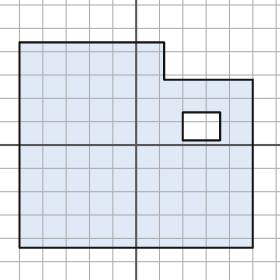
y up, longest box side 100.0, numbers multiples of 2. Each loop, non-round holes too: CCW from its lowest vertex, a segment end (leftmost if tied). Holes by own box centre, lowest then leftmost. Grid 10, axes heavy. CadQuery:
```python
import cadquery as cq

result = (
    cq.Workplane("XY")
    .moveTo(-50.0, -44.0)
    .lineTo(50.0, -44.0)
    .lineTo(50.0, 28.0)
    .lineTo(12.0, 28.0)
    .lineTo(12.0, 44.0)
    .lineTo(-50.0, 44.0)
    .close()
    .moveTo(20.0, 2.0)
    .lineTo(36.0, 2.0)
    .lineTo(36.0, 14.0)
    .lineTo(20.0, 14.0)
    .close()
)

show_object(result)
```